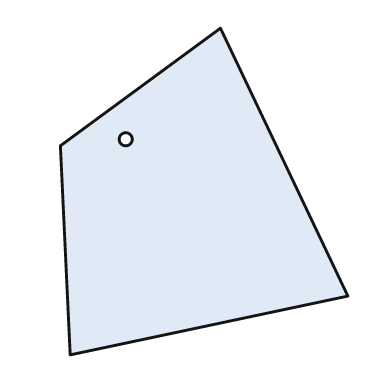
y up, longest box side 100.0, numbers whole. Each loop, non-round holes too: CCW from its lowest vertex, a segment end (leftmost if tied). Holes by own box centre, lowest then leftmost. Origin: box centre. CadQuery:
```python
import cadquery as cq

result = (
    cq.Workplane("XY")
    .moveTo(-41.0, -50.0)
    .lineTo(44.0, -32.0)
    .lineTo(5.0, 50.0)
    .lineTo(-44.0, 14.0)
    .close()
    .moveTo(-24.0, 16.0)
    .circle(2.0)
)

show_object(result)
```